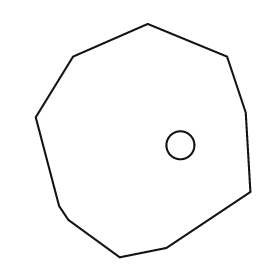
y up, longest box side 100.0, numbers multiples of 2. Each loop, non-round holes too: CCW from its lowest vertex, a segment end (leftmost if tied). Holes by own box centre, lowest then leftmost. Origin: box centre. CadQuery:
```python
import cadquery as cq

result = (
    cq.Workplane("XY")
    .moveTo(-10.0, -50.0)
    .lineTo(10.0, -46.0)
    .lineTo(46.0, -22.0)
    .lineTo(44.0, 12.0)
    .lineTo(36.0, 36.0)
    .lineTo(2.0, 50.0)
    .lineTo(-30.0, 36.0)
    .lineTo(-46.0, 10.0)
    .lineTo(-36.0, -28.0)
    .lineTo(-32.0, -34.0)
    .close()
    .moveTo(16.0, -2.0)
    .circle(6.0)
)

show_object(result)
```